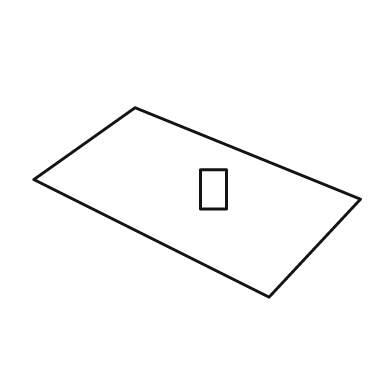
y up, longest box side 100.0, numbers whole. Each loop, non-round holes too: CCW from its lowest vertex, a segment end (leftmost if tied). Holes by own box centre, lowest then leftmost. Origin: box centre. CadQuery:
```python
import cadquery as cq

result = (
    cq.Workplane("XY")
    .moveTo(22.0, -29.0)
    .lineTo(50.0, 1.0)
    .lineTo(-19.0, 29.0)
    .lineTo(-50.0, 7.0)
    .close()
    .moveTo(1.0, -2.0)
    .lineTo(9.0, -2.0)
    .lineTo(9.0, 10.0)
    .lineTo(1.0, 10.0)
    .close()
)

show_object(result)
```